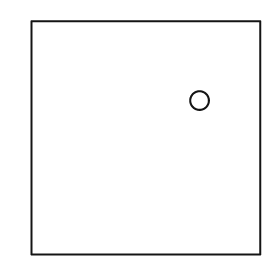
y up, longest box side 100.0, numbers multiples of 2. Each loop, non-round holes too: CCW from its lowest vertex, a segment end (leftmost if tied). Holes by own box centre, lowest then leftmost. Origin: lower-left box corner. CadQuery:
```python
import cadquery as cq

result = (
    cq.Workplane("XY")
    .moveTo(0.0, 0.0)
    .lineTo(98.0, 0.0)
    .lineTo(98.0, 100.0)
    .lineTo(0.0, 100.0)
    .close()
    .moveTo(72.0, 66.0)
    .circle(4.0)
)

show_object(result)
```